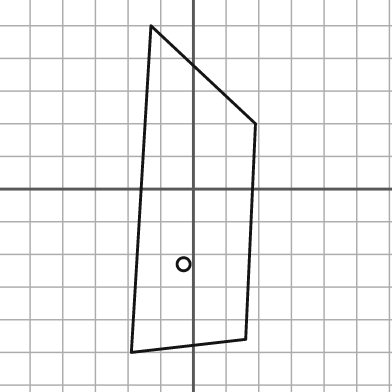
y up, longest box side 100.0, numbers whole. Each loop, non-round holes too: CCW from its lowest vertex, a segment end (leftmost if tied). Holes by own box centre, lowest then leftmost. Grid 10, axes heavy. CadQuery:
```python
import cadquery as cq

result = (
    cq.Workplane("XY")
    .moveTo(-19.0, -50.0)
    .lineTo(16.0, -46.0)
    .lineTo(19.0, 20.0)
    .lineTo(-13.0, 50.0)
    .close()
    .moveTo(-3.0, -23.0)
    .circle(2.0)
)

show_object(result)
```